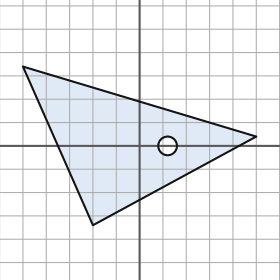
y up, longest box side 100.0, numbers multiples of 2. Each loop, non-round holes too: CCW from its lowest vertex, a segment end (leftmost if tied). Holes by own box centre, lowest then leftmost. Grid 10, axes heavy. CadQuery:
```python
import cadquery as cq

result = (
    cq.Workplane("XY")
    .moveTo(-20.0, -34.0)
    .lineTo(50.0, 4.0)
    .lineTo(-50.0, 34.0)
    .close()
    .moveTo(12.0, 0.0)
    .circle(4.0)
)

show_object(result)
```